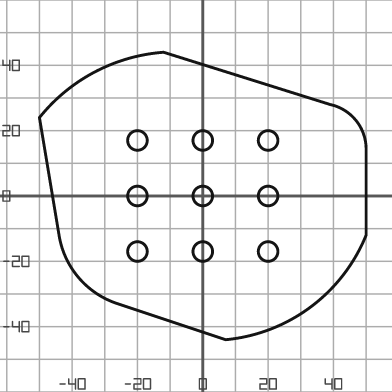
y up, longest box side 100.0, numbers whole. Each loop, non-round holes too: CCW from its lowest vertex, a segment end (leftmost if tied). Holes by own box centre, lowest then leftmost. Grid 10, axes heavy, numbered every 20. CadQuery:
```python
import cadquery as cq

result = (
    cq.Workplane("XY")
    .moveTo(7.0, -44.0)
    .threePointArc((33.0, -34.0), (50.0, -12.0))
    .lineTo(50.0, 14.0)
    .threePointArc((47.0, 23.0), (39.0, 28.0))
    .lineTo(-12.0, 44.0)
    .threePointArc((-33.0, 38.0), (-50.0, 24.0))
    .lineTo(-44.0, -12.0)
    .threePointArc((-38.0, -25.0), (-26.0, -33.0))
    .close()
    .moveTo(-20.0, -17.0)
    .circle(3.0)
    .moveTo(0.0, -17.0)
    .circle(3.0)
    .moveTo(20.0, -17.0)
    .circle(3.0)
    .moveTo(-20.0, 0.0)
    .circle(3.0)
    .moveTo(0.0, 0.0)
    .circle(3.0)
    .moveTo(20.0, 0.0)
    .circle(3.0)
    .moveTo(-20.0, 17.0)
    .circle(3.0)
    .moveTo(0.0, 17.0)
    .circle(3.0)
    .moveTo(20.0, 17.0)
    .circle(3.0)
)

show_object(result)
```